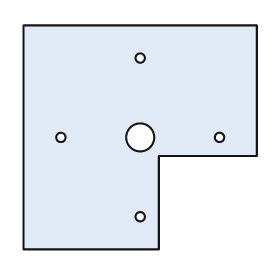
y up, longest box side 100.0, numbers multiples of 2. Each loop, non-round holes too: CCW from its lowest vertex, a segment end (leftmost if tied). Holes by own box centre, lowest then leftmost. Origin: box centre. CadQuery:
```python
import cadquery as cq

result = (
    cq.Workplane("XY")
    .moveTo(-50.0, -48.0)
    .lineTo(8.0, -48.0)
    .lineTo(8.0, -8.0)
    .lineTo(50.0, -8.0)
    .lineTo(50.0, 48.0)
    .lineTo(-50.0, 48.0)
    .close()
    .moveTo(0.0, -34.0)
    .circle(2.0)
    .moveTo(-34.0, 0.0)
    .circle(2.0)
    .moveTo(0.0, 0.0)
    .circle(6.0)
    .moveTo(34.0, 0.0)
    .circle(2.0)
    .moveTo(0.0, 34.0)
    .circle(2.0)
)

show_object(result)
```